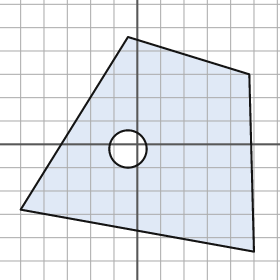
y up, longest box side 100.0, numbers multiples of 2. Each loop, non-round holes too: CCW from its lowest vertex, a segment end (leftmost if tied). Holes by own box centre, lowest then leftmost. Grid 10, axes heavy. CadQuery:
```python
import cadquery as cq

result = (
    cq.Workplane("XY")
    .moveTo(50.0, -46.0)
    .lineTo(48.0, 30.0)
    .lineTo(-4.0, 46.0)
    .lineTo(-50.0, -28.0)
    .close()
    .moveTo(-4.0, -2.0)
    .circle(8.0)
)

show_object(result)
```